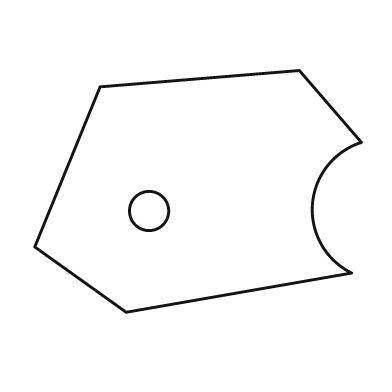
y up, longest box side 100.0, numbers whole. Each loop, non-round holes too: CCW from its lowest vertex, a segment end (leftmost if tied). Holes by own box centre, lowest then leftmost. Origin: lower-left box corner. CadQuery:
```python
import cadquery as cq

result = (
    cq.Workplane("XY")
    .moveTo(28.0, 0.0)
    .lineTo(97.0, 12.0)
    .threePointArc((85.0, 33.0), (100.0, 52.0))
    .lineTo(81.0, 74.0)
    .lineTo(20.0, 69.0)
    .lineTo(0.0, 20.0)
    .close()
    .moveTo(35.0, 31.0)
    .circle(6.0)
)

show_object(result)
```